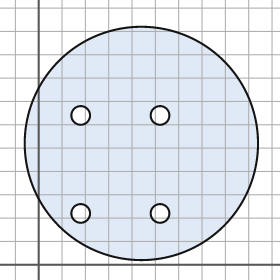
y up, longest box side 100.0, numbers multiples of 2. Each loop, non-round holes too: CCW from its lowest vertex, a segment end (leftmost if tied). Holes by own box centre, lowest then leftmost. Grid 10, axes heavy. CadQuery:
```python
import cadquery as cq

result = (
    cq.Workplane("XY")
    .moveTo(44.0, 52.0)
    .circle(50.0)
    .moveTo(18.0, 22.0)
    .circle(4.0)
    .moveTo(52.0, 22.0)
    .circle(4.0)
    .moveTo(18.0, 64.0)
    .circle(4.0)
    .moveTo(52.0, 64.0)
    .circle(4.0)
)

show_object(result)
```